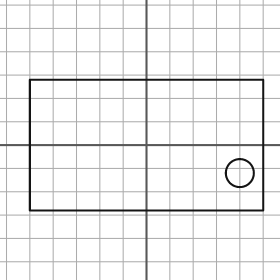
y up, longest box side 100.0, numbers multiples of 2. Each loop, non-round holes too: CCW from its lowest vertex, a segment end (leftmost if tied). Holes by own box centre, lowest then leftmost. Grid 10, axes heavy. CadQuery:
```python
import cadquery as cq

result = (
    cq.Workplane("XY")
    .moveTo(-50.0, -28.0)
    .lineTo(50.0, -28.0)
    .lineTo(50.0, 28.0)
    .lineTo(-50.0, 28.0)
    .close()
    .moveTo(40.0, -12.0)
    .circle(6.0)
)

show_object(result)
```